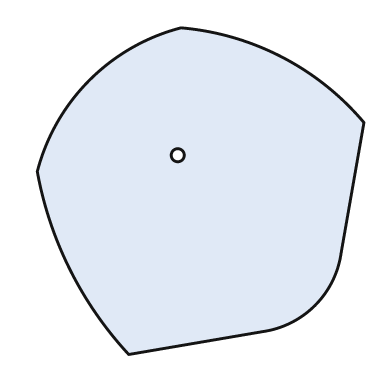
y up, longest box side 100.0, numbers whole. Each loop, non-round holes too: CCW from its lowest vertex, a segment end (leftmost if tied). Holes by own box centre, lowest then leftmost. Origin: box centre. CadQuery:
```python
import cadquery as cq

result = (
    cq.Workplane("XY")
    .moveTo(-22.0, -50.0)
    .lineTo(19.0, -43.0)
    .threePointArc((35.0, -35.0), (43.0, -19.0))
    .lineTo(50.0, 21.0)
    .threePointArc((25.0, 41.0), (-6.0, 50.0))
    .threePointArc((-34.0, 34.0), (-50.0, 6.0))
    .threePointArc((-40.0, -24.0), (-22.0, -50.0))
    .close()
    .moveTo(-7.0, 11.0)
    .circle(2.0)
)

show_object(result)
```